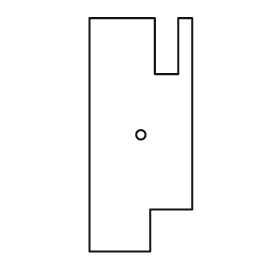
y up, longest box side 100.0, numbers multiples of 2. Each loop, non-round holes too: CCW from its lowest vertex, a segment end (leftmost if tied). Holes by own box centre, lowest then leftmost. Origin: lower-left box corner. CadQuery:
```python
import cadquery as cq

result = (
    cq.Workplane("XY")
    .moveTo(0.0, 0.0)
    .lineTo(26.0, 0.0)
    .lineTo(26.0, 18.0)
    .lineTo(44.0, 18.0)
    .lineTo(44.0, 100.0)
    .lineTo(38.0, 100.0)
    .lineTo(38.0, 76.0)
    .lineTo(28.0, 76.0)
    .lineTo(28.0, 100.0)
    .lineTo(0.0, 100.0)
    .close()
    .moveTo(22.0, 50.0)
    .circle(2.0)
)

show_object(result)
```